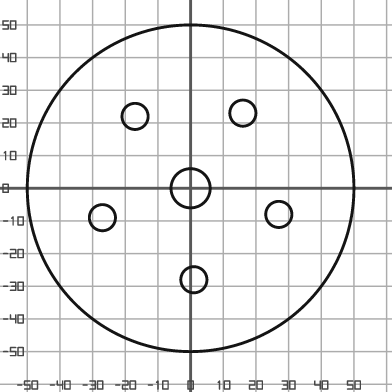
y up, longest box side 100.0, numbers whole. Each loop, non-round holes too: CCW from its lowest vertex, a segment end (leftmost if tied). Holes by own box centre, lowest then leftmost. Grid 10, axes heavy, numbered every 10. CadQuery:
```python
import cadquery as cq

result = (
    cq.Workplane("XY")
    .moveTo(0.0, 0.0)
    .circle(50.0)
    .moveTo(1.0, -28.0)
    .circle(4.0)
    .moveTo(-27.0, -9.0)
    .circle(4.0)
    .moveTo(27.0, -8.0)
    .circle(4.0)
    .moveTo(0.0, 0.0)
    .circle(6.0)
    .moveTo(-17.0, 22.0)
    .circle(4.0)
    .moveTo(16.0, 23.0)
    .circle(4.0)
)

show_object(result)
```